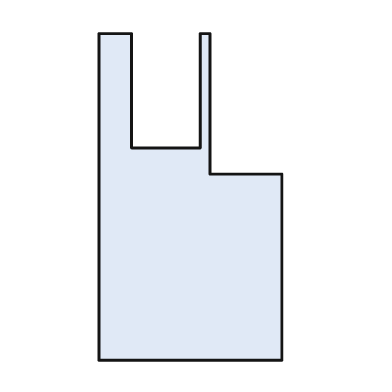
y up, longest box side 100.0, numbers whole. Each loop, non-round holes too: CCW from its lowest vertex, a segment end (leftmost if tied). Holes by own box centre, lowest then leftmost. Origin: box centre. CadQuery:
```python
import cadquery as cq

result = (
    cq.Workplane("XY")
    .moveTo(-28.0, -50.0)
    .lineTo(28.0, -50.0)
    .lineTo(28.0, 7.0)
    .lineTo(6.0, 7.0)
    .lineTo(6.0, 50.0)
    .lineTo(3.0, 50.0)
    .lineTo(3.0, 15.0)
    .lineTo(-18.0, 15.0)
    .lineTo(-18.0, 50.0)
    .lineTo(-28.0, 50.0)
    .close()
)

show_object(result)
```